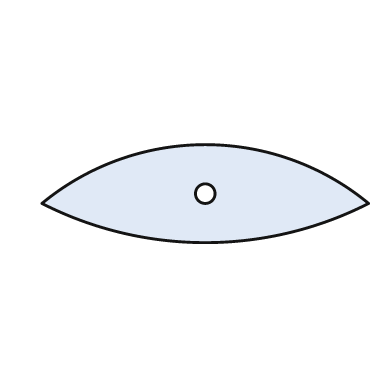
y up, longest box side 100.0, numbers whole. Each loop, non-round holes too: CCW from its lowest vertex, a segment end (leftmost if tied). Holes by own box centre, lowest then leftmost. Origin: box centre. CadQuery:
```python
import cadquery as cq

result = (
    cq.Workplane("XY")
    .moveTo(-50.0, -3.0)
    .threePointArc((0.0, -15.0), (50.0, -3.0))
    .threePointArc((0.0, 15.0), (-50.0, -3.0))
    .close()
    .moveTo(0.0, 0.0)
    .circle(3.0)
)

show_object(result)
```